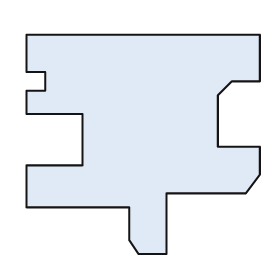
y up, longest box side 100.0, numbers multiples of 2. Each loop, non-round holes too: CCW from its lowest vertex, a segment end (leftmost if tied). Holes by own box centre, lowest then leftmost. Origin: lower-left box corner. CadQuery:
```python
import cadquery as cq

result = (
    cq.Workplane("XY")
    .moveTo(48.0, 0.0)
    .lineTo(60.0, 0.0)
    .lineTo(60.0, 26.0)
    .lineTo(94.0, 26.0)
    .lineTo(100.0, 34.0)
    .lineTo(100.0, 46.0)
    .lineTo(82.0, 46.0)
    .lineTo(82.0, 68.0)
    .lineTo(88.0, 74.0)
    .lineTo(100.0, 74.0)
    .lineTo(100.0, 94.0)
    .lineTo(0.0, 94.0)
    .lineTo(0.0, 78.0)
    .lineTo(8.0, 78.0)
    .lineTo(8.0, 70.0)
    .lineTo(0.0, 70.0)
    .lineTo(0.0, 60.0)
    .lineTo(24.0, 60.0)
    .lineTo(24.0, 38.0)
    .lineTo(0.0, 38.0)
    .lineTo(0.0, 20.0)
    .lineTo(44.0, 20.0)
    .lineTo(44.0, 6.0)
    .close()
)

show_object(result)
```